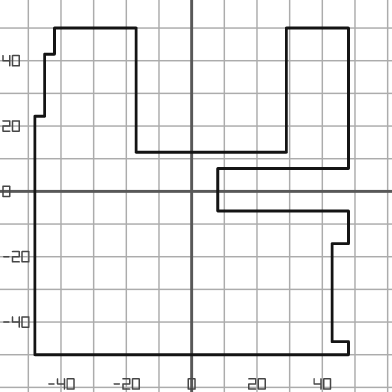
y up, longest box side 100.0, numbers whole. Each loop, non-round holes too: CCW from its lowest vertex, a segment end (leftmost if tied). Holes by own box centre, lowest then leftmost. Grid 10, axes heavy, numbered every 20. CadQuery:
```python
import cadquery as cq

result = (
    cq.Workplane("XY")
    .moveTo(-48.0, -50.0)
    .lineTo(48.0, -50.0)
    .lineTo(48.0, -46.0)
    .lineTo(43.0, -46.0)
    .lineTo(43.0, -16.0)
    .lineTo(48.0, -16.0)
    .lineTo(48.0, -6.0)
    .lineTo(8.0, -6.0)
    .lineTo(8.0, 7.0)
    .lineTo(48.0, 7.0)
    .lineTo(48.0, 50.0)
    .lineTo(29.0, 50.0)
    .lineTo(29.0, 12.0)
    .lineTo(-17.0, 12.0)
    .lineTo(-17.0, 50.0)
    .lineTo(-42.0, 50.0)
    .lineTo(-42.0, 42.0)
    .lineTo(-45.0, 42.0)
    .lineTo(-45.0, 23.0)
    .lineTo(-48.0, 23.0)
    .close()
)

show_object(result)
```